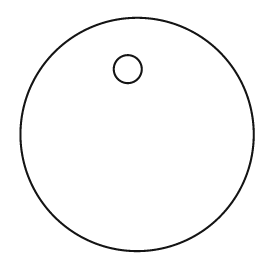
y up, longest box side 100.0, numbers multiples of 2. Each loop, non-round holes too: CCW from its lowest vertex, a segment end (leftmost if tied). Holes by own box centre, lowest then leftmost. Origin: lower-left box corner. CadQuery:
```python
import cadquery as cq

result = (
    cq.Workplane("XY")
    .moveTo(50.0, 50.0)
    .circle(50.0)
    .moveTo(46.0, 78.0)
    .circle(6.0)
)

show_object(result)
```